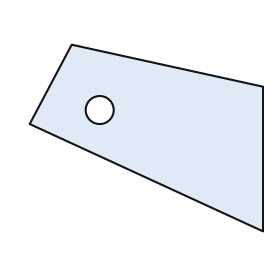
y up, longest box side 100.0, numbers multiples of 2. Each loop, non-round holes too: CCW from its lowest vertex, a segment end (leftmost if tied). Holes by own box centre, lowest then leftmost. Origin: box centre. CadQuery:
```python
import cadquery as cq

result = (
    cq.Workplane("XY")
    .moveTo(50.0, -40.0)
    .lineTo(50.0, 22.0)
    .lineTo(-32.0, 40.0)
    .lineTo(-50.0, 6.0)
    .close()
    .moveTo(-20.0, 12.0)
    .circle(6.0)
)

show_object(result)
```